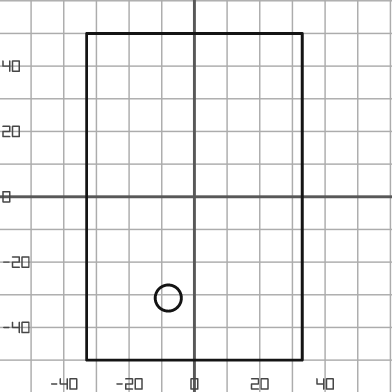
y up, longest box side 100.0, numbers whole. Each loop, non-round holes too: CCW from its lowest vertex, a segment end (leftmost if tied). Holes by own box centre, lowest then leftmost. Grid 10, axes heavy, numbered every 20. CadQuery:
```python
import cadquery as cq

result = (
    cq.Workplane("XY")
    .moveTo(-33.0, -50.0)
    .lineTo(33.0, -50.0)
    .lineTo(33.0, 50.0)
    .lineTo(-33.0, 50.0)
    .close()
    .moveTo(-8.0, -31.0)
    .circle(4.0)
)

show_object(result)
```